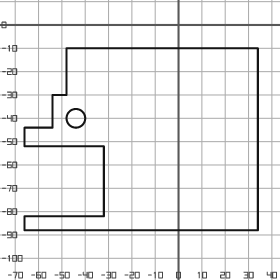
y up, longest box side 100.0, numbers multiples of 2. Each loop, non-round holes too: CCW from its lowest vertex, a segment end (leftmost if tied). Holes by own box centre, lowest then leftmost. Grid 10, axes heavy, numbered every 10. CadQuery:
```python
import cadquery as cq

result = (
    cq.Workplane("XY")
    .moveTo(-66.0, -88.0)
    .lineTo(34.0, -88.0)
    .lineTo(34.0, -10.0)
    .lineTo(-48.0, -10.0)
    .lineTo(-48.0, -30.0)
    .lineTo(-54.0, -30.0)
    .lineTo(-54.0, -44.0)
    .lineTo(-66.0, -44.0)
    .lineTo(-66.0, -52.0)
    .lineTo(-32.0, -52.0)
    .lineTo(-32.0, -82.0)
    .lineTo(-66.0, -82.0)
    .close()
    .moveTo(-44.0, -40.0)
    .circle(4.0)
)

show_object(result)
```